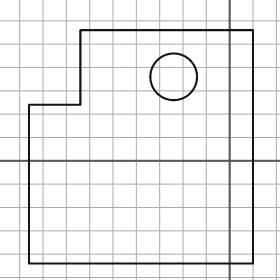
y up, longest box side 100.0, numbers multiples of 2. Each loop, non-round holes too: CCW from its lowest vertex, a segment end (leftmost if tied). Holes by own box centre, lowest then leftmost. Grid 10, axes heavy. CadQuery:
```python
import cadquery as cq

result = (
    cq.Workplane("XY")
    .moveTo(-86.0, -44.0)
    .lineTo(10.0, -44.0)
    .lineTo(10.0, 56.0)
    .lineTo(-64.0, 56.0)
    .lineTo(-64.0, 24.0)
    .lineTo(-86.0, 24.0)
    .close()
    .moveTo(-24.0, 36.0)
    .circle(10.0)
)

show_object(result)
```